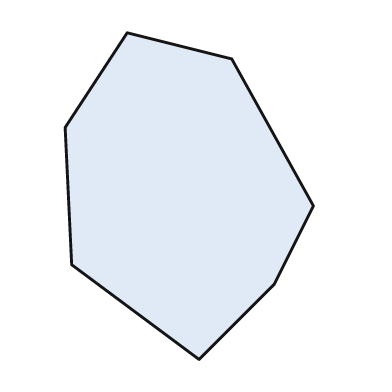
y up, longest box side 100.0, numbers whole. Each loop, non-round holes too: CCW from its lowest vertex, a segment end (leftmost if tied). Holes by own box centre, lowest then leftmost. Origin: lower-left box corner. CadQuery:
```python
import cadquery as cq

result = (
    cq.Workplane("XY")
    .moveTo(41.0, 0.0)
    .lineTo(64.0, 23.0)
    .lineTo(76.0, 47.0)
    .lineTo(51.0, 92.0)
    .lineTo(19.0, 100.0)
    .lineTo(0.0, 71.0)
    .lineTo(2.0, 29.0)
    .close()
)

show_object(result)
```